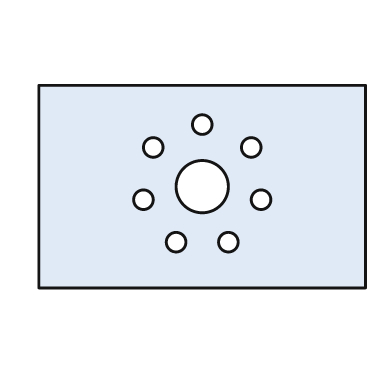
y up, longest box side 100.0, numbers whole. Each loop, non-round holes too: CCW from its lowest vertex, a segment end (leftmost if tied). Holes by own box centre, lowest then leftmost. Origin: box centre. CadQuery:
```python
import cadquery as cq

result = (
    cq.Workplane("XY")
    .moveTo(-50.0, -31.0)
    .lineTo(50.0, -31.0)
    .lineTo(50.0, 31.0)
    .lineTo(-50.0, 31.0)
    .close()
    .moveTo(-8.0, -17.0)
    .circle(3.0)
    .moveTo(8.0, -17.0)
    .circle(3.0)
    .moveTo(-18.0, -4.0)
    .circle(3.0)
    .moveTo(18.0, -4.0)
    .circle(3.0)
    .moveTo(0.0, 0.0)
    .circle(8.0)
    .moveTo(-15.0, 12.0)
    .circle(3.0)
    .moveTo(15.0, 12.0)
    .circle(3.0)
    .moveTo(0.0, 19.0)
    .circle(3.0)
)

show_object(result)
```